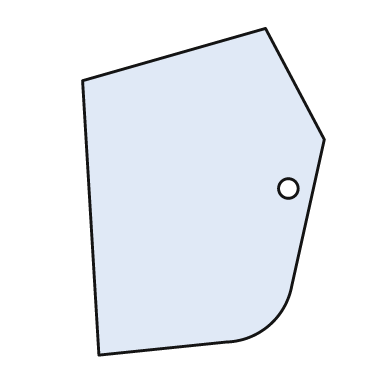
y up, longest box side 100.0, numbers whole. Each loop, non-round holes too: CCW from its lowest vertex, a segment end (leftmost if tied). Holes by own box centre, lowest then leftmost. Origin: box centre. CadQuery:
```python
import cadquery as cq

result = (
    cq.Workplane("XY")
    .moveTo(-32.0, -50.0)
    .lineTo(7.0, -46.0)
    .threePointArc((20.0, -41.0), (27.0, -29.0))
    .lineTo(37.0, 16.0)
    .lineTo(19.0, 50.0)
    .lineTo(-37.0, 34.0)
    .close()
    .moveTo(26.0, 1.0)
    .circle(3.0)
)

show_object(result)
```